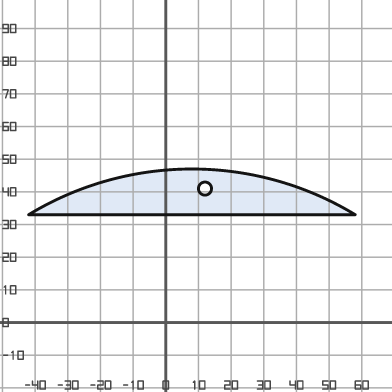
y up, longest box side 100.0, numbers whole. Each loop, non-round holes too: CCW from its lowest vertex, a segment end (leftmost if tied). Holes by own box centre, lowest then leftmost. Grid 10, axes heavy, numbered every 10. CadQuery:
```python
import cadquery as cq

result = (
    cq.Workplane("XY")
    .moveTo(-42.0, 33.0)
    .lineTo(58.0, 33.0)
    .threePointArc((8.0, 47.0), (-42.0, 33.0))
    .close()
    .moveTo(12.0, 41.0)
    .circle(2.0)
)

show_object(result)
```